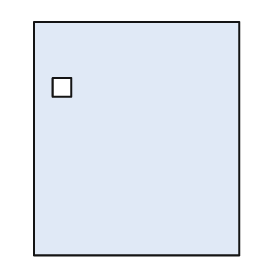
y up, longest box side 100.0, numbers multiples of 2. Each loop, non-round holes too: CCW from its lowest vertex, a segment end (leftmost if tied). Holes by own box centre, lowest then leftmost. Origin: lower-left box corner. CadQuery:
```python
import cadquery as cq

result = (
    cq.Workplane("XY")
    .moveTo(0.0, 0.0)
    .lineTo(88.0, 0.0)
    .lineTo(88.0, 100.0)
    .lineTo(0.0, 100.0)
    .close()
    .moveTo(8.0, 68.0)
    .lineTo(16.0, 68.0)
    .lineTo(16.0, 76.0)
    .lineTo(8.0, 76.0)
    .close()
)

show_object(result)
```